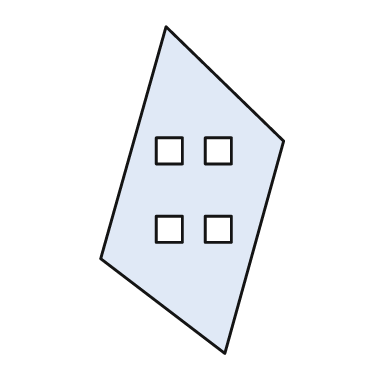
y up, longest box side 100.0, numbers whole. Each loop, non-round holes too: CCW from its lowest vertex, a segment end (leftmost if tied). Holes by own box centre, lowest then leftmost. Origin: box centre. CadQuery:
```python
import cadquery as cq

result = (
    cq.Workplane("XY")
    .moveTo(10.0, -50.0)
    .lineTo(28.0, 15.0)
    .lineTo(-8.0, 50.0)
    .lineTo(-28.0, -21.0)
    .close()
    .moveTo(-11.0, -16.0)
    .lineTo(-3.0, -16.0)
    .lineTo(-3.0, -8.0)
    .lineTo(-11.0, -8.0)
    .close()
    .moveTo(4.0, -16.0)
    .lineTo(12.0, -16.0)
    .lineTo(12.0, -8.0)
    .lineTo(4.0, -8.0)
    .close()
    .moveTo(-11.0, 8.0)
    .lineTo(-3.0, 8.0)
    .lineTo(-3.0, 16.0)
    .lineTo(-11.0, 16.0)
    .close()
    .moveTo(4.0, 8.0)
    .lineTo(12.0, 8.0)
    .lineTo(12.0, 16.0)
    .lineTo(4.0, 16.0)
    .close()
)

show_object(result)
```